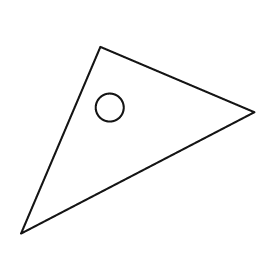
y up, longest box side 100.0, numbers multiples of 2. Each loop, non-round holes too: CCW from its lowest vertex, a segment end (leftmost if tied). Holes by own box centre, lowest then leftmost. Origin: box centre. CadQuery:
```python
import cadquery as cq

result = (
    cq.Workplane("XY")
    .moveTo(-50.0, -40.0)
    .lineTo(50.0, 12.0)
    .lineTo(-16.0, 40.0)
    .close()
    .moveTo(-12.0, 14.0)
    .circle(6.0)
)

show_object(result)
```